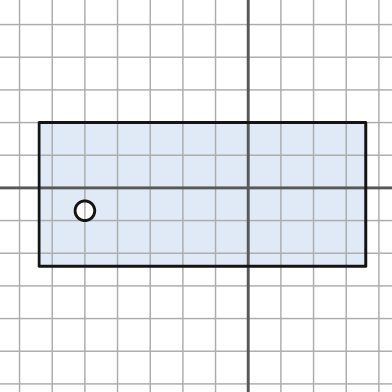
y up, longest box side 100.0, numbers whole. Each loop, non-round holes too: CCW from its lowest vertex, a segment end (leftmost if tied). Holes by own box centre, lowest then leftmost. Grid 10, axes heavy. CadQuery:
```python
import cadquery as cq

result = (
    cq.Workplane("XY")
    .moveTo(-64.0, -24.0)
    .lineTo(36.0, -24.0)
    .lineTo(36.0, 20.0)
    .lineTo(-64.0, 20.0)
    .close()
    .moveTo(-50.0, -7.0)
    .circle(3.0)
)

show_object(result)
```